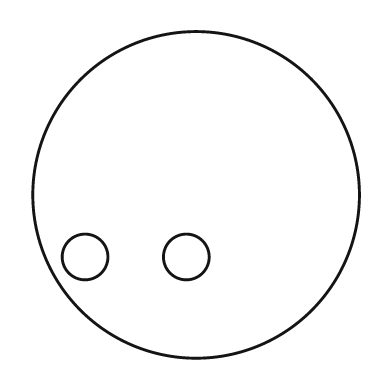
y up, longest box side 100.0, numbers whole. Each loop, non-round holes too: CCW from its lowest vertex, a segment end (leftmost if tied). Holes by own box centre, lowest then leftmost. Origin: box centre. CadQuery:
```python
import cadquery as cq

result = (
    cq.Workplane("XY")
    .moveTo(0.0, 0.0)
    .circle(50.0)
    .moveTo(-34.0, -19.0)
    .circle(7.0)
    .moveTo(-3.0, -19.0)
    .circle(7.0)
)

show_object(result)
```